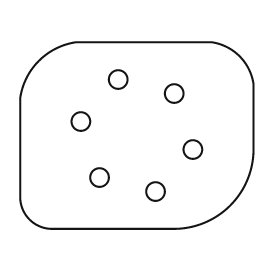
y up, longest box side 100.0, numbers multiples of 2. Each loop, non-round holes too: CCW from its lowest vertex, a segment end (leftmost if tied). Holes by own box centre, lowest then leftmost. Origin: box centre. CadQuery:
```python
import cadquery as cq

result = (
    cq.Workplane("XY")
    .moveTo(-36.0, -40.0)
    .lineTo(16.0, -40.0)
    .threePointArc((40.0, -30.0), (50.0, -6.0))
    .lineTo(50.0, 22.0)
    .threePointArc((44.0, 34.0), (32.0, 40.0))
    .lineTo(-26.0, 40.0)
    .threePointArc((-42.0, 32.0), (-50.0, 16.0))
    .lineTo(-50.0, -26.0)
    .threePointArc((-46.0, -36.0), (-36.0, -40.0))
    .close()
    .moveTo(8.0, -24.0)
    .circle(4.0)
    .moveTo(-16.0, -18.0)
    .circle(4.0)
    .moveTo(24.0, -6.0)
    .circle(4.0)
    .moveTo(-24.0, 6.0)
    .circle(4.0)
    .moveTo(16.0, 18.0)
    .circle(4.0)
    .moveTo(-8.0, 24.0)
    .circle(4.0)
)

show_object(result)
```